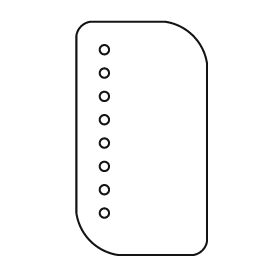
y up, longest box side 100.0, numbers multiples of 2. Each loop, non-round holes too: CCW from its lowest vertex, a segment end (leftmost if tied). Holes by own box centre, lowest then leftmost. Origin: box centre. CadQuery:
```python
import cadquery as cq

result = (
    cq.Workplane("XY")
    .moveTo(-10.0, -50.0)
    .lineTo(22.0, -50.0)
    .threePointArc((26.0, -48.0), (28.0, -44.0))
    .lineTo(28.0, 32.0)
    .threePointArc((22.0, 44.0), (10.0, 50.0))
    .lineTo(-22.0, 50.0)
    .threePointArc((-26.0, 48.0), (-28.0, 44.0))
    .lineTo(-28.0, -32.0)
    .threePointArc((-22.0, -44.0), (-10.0, -50.0))
    .close()
    .moveTo(-16.0, -32.0)
    .circle(2.0)
    .moveTo(-16.0, -22.0)
    .circle(2.0)
    .moveTo(-16.0, -12.0)
    .circle(2.0)
    .moveTo(-16.0, -2.0)
    .circle(2.0)
    .moveTo(-16.0, 8.0)
    .circle(2.0)
    .moveTo(-16.0, 18.0)
    .circle(2.0)
    .moveTo(-16.0, 28.0)
    .circle(2.0)
    .moveTo(-16.0, 38.0)
    .circle(2.0)
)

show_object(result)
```